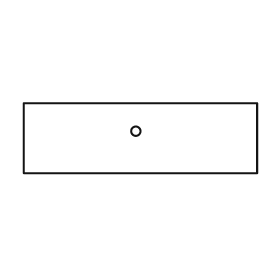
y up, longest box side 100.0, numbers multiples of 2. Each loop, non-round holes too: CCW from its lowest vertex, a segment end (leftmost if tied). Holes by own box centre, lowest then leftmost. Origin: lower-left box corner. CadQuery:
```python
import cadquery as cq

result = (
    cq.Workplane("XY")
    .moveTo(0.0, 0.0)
    .lineTo(100.0, 0.0)
    .lineTo(100.0, 30.0)
    .lineTo(0.0, 30.0)
    .close()
    .moveTo(48.0, 18.0)
    .circle(2.0)
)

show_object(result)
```